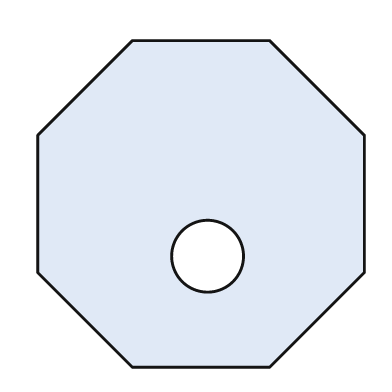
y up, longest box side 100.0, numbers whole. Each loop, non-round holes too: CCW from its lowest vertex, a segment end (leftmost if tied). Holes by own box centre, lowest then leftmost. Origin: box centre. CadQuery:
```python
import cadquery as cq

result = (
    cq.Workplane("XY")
    .moveTo(-21.0, -50.0)
    .lineTo(21.0, -50.0)
    .lineTo(50.0, -21.0)
    .lineTo(50.0, 21.0)
    .lineTo(21.0, 50.0)
    .lineTo(-21.0, 50.0)
    .lineTo(-50.0, 21.0)
    .lineTo(-50.0, -21.0)
    .close()
    .moveTo(2.0, -16.0)
    .circle(11.0)
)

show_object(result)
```